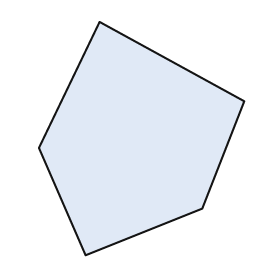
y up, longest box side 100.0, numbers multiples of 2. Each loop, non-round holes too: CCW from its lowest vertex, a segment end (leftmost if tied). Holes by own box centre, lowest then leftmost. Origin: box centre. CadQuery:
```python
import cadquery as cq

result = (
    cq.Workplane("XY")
    .moveTo(-24.0, -50.0)
    .lineTo(26.0, -30.0)
    .lineTo(44.0, 16.0)
    .lineTo(-18.0, 50.0)
    .lineTo(-44.0, -4.0)
    .close()
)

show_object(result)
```